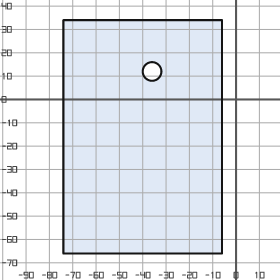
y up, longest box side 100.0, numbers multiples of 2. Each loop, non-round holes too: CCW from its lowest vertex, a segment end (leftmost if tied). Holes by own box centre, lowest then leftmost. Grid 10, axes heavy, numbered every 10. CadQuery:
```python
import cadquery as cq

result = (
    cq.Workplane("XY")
    .moveTo(-74.0, -66.0)
    .lineTo(-6.0, -66.0)
    .lineTo(-6.0, 34.0)
    .lineTo(-74.0, 34.0)
    .close()
    .moveTo(-36.0, 12.0)
    .circle(4.0)
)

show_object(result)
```